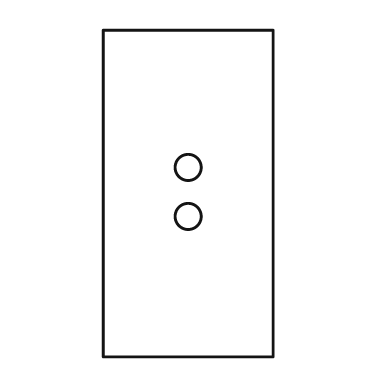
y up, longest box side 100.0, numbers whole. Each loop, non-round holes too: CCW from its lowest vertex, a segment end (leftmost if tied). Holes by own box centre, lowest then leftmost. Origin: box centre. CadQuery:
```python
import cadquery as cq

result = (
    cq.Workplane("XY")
    .moveTo(-26.0, -50.0)
    .lineTo(26.0, -50.0)
    .lineTo(26.0, 50.0)
    .lineTo(-26.0, 50.0)
    .close()
    .moveTo(0.0, -7.0)
    .circle(4.0)
    .moveTo(0.0, 8.0)
    .circle(4.0)
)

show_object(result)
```